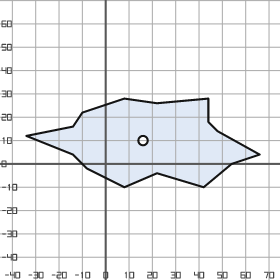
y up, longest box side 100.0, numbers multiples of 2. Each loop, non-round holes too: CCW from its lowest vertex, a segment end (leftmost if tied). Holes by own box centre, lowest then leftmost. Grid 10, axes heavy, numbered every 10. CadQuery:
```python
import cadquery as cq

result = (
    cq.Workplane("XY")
    .moveTo(8.0, -10.0)
    .lineTo(22.0, -4.0)
    .lineTo(42.0, -10.0)
    .lineTo(54.0, 0.0)
    .lineTo(66.0, 4.0)
    .lineTo(48.0, 14.0)
    .lineTo(44.0, 18.0)
    .lineTo(44.0, 28.0)
    .lineTo(22.0, 26.0)
    .lineTo(8.0, 28.0)
    .lineTo(-10.0, 22.0)
    .lineTo(-14.0, 16.0)
    .lineTo(-34.0, 12.0)
    .lineTo(-14.0, 4.0)
    .lineTo(-8.0, -2.0)
    .close()
    .moveTo(16.0, 10.0)
    .circle(2.0)
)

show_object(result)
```